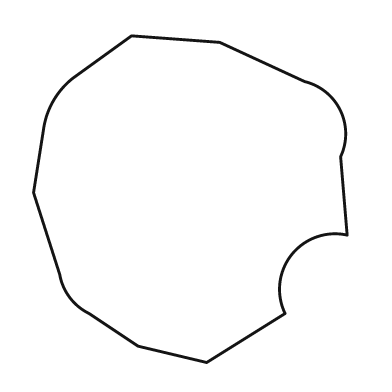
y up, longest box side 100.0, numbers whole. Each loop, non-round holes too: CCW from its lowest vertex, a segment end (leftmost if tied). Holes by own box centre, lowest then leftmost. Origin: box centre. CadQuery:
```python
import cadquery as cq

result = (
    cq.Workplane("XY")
    .moveTo(5.0, -50.0)
    .lineTo(29.0, -35.0)
    .threePointArc((31.0, -17.0), (48.0, -11.0))
    .lineTo(46.0, 13.0)
    .threePointArc((46.0, 27.0), (35.0, 36.0))
    .lineTo(9.0, 48.0)
    .lineTo(-18.0, 50.0)
    .lineTo(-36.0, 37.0)
    .threePointArc((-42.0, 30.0), (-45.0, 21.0))
    .lineTo(-48.0, 2.0)
    .lineTo(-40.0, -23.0)
    .threePointArc((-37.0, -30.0), (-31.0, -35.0))
    .lineTo(-16.0, -45.0)
    .close()
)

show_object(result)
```